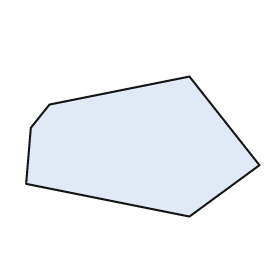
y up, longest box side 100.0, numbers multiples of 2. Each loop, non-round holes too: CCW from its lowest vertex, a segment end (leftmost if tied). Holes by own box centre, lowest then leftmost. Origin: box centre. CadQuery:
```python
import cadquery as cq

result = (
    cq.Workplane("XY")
    .moveTo(20.0, -30.0)
    .lineTo(50.0, -8.0)
    .lineTo(20.0, 30.0)
    .lineTo(-40.0, 18.0)
    .lineTo(-48.0, 8.0)
    .lineTo(-50.0, -16.0)
    .close()
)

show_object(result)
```